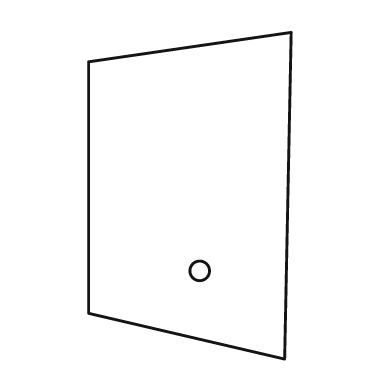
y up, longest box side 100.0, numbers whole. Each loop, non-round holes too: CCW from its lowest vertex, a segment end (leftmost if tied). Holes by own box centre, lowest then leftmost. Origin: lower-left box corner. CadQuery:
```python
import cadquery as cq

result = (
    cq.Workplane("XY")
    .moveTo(60.0, 0.0)
    .lineTo(62.0, 100.0)
    .lineTo(0.0, 91.0)
    .lineTo(0.0, 14.0)
    .close()
    .moveTo(34.0, 27.0)
    .circle(3.0)
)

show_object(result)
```